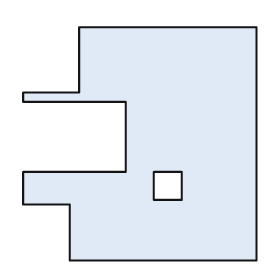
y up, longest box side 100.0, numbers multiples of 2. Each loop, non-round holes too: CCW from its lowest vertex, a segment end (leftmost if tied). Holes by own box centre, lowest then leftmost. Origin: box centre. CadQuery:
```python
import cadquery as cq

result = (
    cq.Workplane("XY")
    .moveTo(-30.0, -50.0)
    .lineTo(50.0, -50.0)
    .lineTo(50.0, 50.0)
    .lineTo(-26.0, 50.0)
    .lineTo(-26.0, 22.0)
    .lineTo(-50.0, 22.0)
    .lineTo(-50.0, 18.0)
    .lineTo(-6.0, 18.0)
    .lineTo(-6.0, -12.0)
    .lineTo(-50.0, -12.0)
    .lineTo(-50.0, -26.0)
    .lineTo(-30.0, -26.0)
    .close()
    .moveTo(6.0, -24.0)
    .lineTo(18.0, -24.0)
    .lineTo(18.0, -12.0)
    .lineTo(6.0, -12.0)
    .close()
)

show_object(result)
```